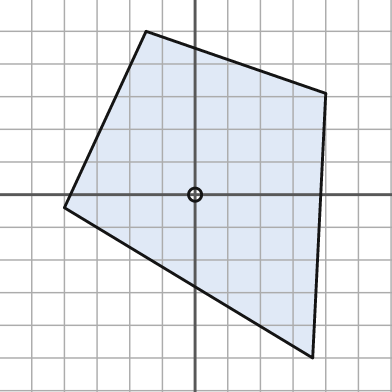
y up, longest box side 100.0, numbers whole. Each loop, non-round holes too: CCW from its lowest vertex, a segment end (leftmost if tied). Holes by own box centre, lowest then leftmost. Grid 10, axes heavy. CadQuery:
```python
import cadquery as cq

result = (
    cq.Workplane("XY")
    .moveTo(36.0, -50.0)
    .lineTo(40.0, 31.0)
    .lineTo(-15.0, 50.0)
    .lineTo(-40.0, -4.0)
    .close()
    .moveTo(0.0, 0.0)
    .circle(2.0)
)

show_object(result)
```